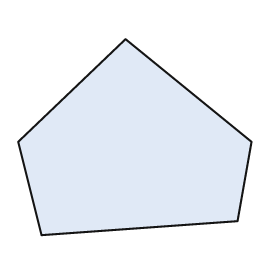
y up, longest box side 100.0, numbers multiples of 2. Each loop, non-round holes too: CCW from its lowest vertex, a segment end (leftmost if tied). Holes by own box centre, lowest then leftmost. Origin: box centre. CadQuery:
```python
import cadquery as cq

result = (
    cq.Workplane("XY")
    .moveTo(-40.0, -42.0)
    .lineTo(44.0, -36.0)
    .lineTo(50.0, -2.0)
    .lineTo(-4.0, 42.0)
    .lineTo(-50.0, -2.0)
    .close()
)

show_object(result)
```